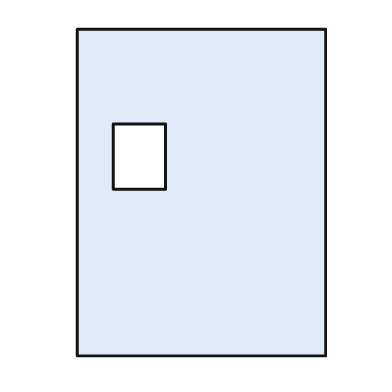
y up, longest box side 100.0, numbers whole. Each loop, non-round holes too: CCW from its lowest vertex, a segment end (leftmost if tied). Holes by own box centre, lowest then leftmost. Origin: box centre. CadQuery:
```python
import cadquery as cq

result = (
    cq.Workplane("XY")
    .moveTo(-38.0, -50.0)
    .lineTo(38.0, -50.0)
    .lineTo(38.0, 50.0)
    .lineTo(-38.0, 50.0)
    .close()
    .moveTo(-27.0, 1.0)
    .lineTo(-11.0, 1.0)
    .lineTo(-11.0, 21.0)
    .lineTo(-27.0, 21.0)
    .close()
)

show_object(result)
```